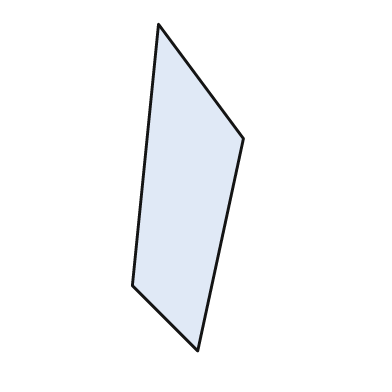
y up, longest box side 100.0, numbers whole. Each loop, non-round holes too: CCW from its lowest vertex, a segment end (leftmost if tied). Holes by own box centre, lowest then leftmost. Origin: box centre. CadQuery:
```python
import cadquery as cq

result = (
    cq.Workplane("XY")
    .moveTo(3.0, -50.0)
    .lineTo(17.0, 15.0)
    .lineTo(-9.0, 50.0)
    .lineTo(-17.0, -30.0)
    .close()
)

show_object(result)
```